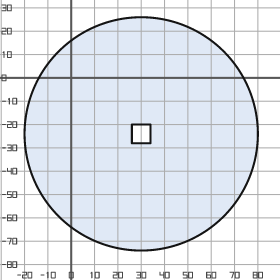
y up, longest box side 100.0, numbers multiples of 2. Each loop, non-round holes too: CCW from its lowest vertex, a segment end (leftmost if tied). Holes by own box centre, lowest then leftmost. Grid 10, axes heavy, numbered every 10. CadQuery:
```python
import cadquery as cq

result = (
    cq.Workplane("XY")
    .moveTo(30.0, -24.0)
    .circle(50.0)
    .moveTo(26.0, -28.0)
    .lineTo(34.0, -28.0)
    .lineTo(34.0, -20.0)
    .lineTo(26.0, -20.0)
    .close()
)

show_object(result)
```